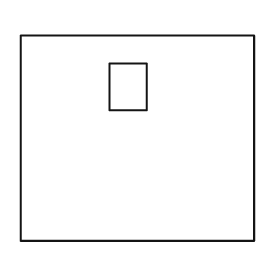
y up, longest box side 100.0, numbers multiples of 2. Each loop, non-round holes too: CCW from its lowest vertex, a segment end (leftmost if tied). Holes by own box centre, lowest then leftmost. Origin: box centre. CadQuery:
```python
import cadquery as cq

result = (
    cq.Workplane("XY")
    .moveTo(-50.0, -44.0)
    .lineTo(50.0, -44.0)
    .lineTo(50.0, 44.0)
    .lineTo(-50.0, 44.0)
    .close()
    .moveTo(-12.0, 12.0)
    .lineTo(4.0, 12.0)
    .lineTo(4.0, 32.0)
    .lineTo(-12.0, 32.0)
    .close()
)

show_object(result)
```